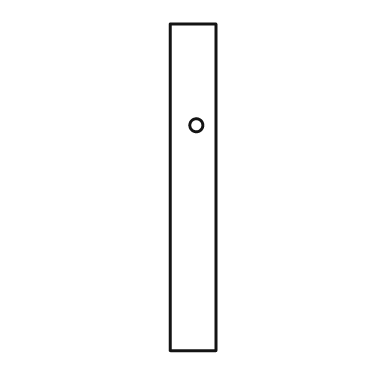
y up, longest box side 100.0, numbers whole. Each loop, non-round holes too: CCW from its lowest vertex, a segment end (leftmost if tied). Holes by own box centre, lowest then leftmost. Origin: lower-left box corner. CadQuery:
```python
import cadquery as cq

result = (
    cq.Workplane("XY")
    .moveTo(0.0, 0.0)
    .lineTo(14.0, 0.0)
    .lineTo(14.0, 100.0)
    .lineTo(0.0, 100.0)
    .close()
    .moveTo(8.0, 69.0)
    .circle(2.0)
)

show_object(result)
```